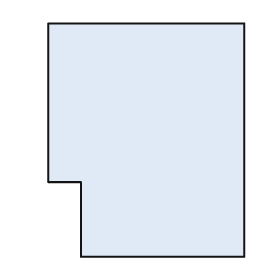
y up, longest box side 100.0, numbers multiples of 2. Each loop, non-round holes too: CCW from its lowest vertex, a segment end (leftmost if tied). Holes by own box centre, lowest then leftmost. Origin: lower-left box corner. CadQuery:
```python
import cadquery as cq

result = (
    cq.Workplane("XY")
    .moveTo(14.0, 0.0)
    .lineTo(84.0, 0.0)
    .lineTo(84.0, 100.0)
    .lineTo(0.0, 100.0)
    .lineTo(0.0, 32.0)
    .lineTo(14.0, 32.0)
    .close()
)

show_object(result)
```